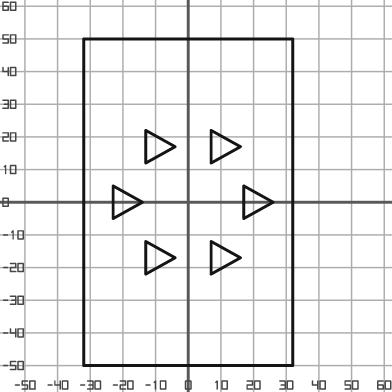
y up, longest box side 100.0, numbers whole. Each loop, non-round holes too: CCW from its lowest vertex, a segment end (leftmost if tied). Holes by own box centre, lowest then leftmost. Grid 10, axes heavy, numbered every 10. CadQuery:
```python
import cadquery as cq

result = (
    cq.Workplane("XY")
    .moveTo(-32.0, -50.0)
    .lineTo(32.0, -50.0)
    .lineTo(32.0, 50.0)
    .lineTo(-32.0, 50.0)
    .close()
    .moveTo(-13.0, -22.0)
    .lineTo(-4.0, -17.0)
    .lineTo(-13.0, -12.0)
    .close()
    .moveTo(7.0, -22.0)
    .lineTo(16.0, -17.0)
    .lineTo(7.0, -12.0)
    .close()
    .moveTo(-23.0, -5.0)
    .lineTo(-14.0, 0.0)
    .lineTo(-23.0, 5.0)
    .close()
    .moveTo(17.0, -5.0)
    .lineTo(26.0, 0.0)
    .lineTo(17.0, 5.0)
    .close()
    .moveTo(-13.0, 12.0)
    .lineTo(-4.0, 17.0)
    .lineTo(-13.0, 22.0)
    .close()
    .moveTo(7.0, 12.0)
    .lineTo(16.0, 17.0)
    .lineTo(7.0, 22.0)
    .close()
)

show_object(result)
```